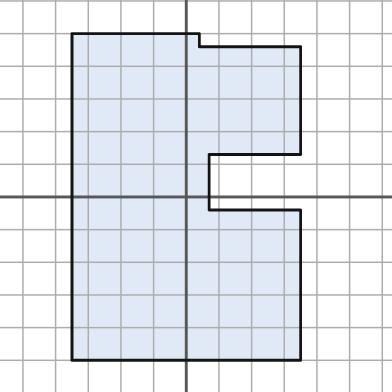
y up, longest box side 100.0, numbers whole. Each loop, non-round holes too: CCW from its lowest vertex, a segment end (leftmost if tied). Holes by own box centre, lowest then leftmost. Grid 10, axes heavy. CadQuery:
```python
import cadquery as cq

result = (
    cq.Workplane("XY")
    .moveTo(-35.0, -50.0)
    .lineTo(35.0, -50.0)
    .lineTo(35.0, -4.0)
    .lineTo(7.0, -4.0)
    .lineTo(7.0, 13.0)
    .lineTo(35.0, 13.0)
    .lineTo(35.0, 46.0)
    .lineTo(4.0, 46.0)
    .lineTo(4.0, 50.0)
    .lineTo(-35.0, 50.0)
    .close()
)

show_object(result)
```